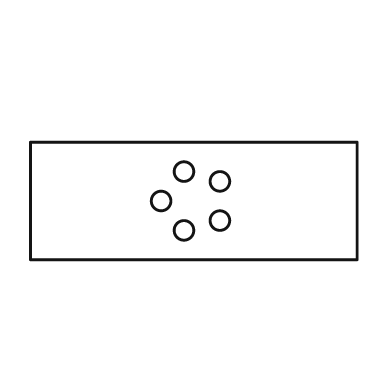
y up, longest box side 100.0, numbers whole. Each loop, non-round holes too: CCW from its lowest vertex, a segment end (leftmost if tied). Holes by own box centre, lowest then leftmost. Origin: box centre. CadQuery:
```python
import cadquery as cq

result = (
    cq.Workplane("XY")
    .moveTo(-50.0, -18.0)
    .lineTo(50.0, -18.0)
    .lineTo(50.0, 18.0)
    .lineTo(-50.0, 18.0)
    .close()
    .moveTo(-3.0, -9.0)
    .circle(3.0)
    .moveTo(8.0, -6.0)
    .circle(3.0)
    .moveTo(-10.0, 0.0)
    .circle(3.0)
    .moveTo(8.0, 6.0)
    .circle(3.0)
    .moveTo(-3.0, 9.0)
    .circle(3.0)
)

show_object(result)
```